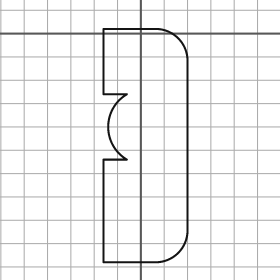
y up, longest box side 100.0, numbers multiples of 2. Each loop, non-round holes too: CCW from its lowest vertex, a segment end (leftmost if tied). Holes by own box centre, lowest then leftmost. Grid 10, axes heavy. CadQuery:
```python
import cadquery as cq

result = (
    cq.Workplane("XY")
    .moveTo(-16.0, -98.0)
    .lineTo(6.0, -98.0)
    .threePointArc((16.0, -94.0), (20.0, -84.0))
    .lineTo(20.0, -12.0)
    .threePointArc((16.0, -2.0), (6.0, 2.0))
    .lineTo(-16.0, 2.0)
    .lineTo(-16.0, -26.0)
    .lineTo(-6.0, -26.0)
    .threePointArc((-14.0, -40.0), (-6.0, -54.0))
    .lineTo(-16.0, -54.0)
    .close()
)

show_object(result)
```